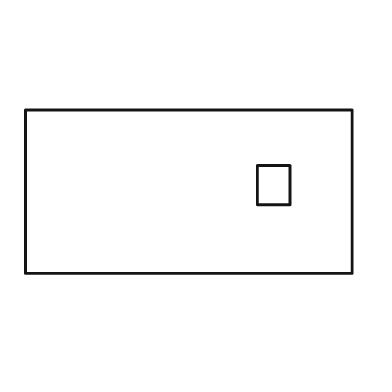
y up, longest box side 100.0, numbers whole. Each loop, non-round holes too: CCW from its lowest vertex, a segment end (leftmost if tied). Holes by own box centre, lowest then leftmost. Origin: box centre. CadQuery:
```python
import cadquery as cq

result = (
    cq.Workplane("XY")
    .moveTo(-50.0, -25.0)
    .lineTo(50.0, -25.0)
    .lineTo(50.0, 25.0)
    .lineTo(-50.0, 25.0)
    .close()
    .moveTo(21.0, -4.0)
    .lineTo(31.0, -4.0)
    .lineTo(31.0, 8.0)
    .lineTo(21.0, 8.0)
    .close()
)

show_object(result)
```